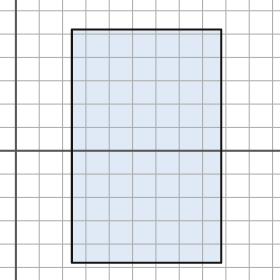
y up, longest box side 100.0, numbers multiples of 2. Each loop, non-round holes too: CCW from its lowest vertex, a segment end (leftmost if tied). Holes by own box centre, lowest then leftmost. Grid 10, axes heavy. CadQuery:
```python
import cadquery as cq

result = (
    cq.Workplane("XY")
    .moveTo(24.0, -48.0)
    .lineTo(88.0, -48.0)
    .lineTo(88.0, 52.0)
    .lineTo(24.0, 52.0)
    .close()
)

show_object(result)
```